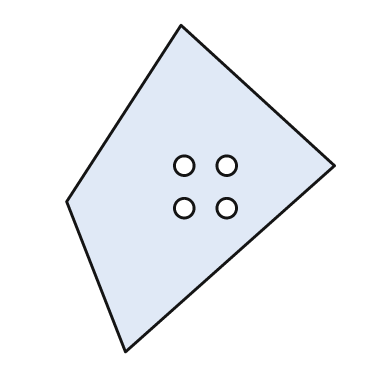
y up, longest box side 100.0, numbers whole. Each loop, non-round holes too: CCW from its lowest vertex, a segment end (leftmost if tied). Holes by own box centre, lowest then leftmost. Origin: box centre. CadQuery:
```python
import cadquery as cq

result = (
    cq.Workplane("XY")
    .moveTo(-23.0, -50.0)
    .lineTo(41.0, 7.0)
    .lineTo(-6.0, 50.0)
    .lineTo(-41.0, -4.0)
    .close()
    .moveTo(-5.0, -6.0)
    .circle(3.0)
    .moveTo(8.0, -6.0)
    .circle(3.0)
    .moveTo(-5.0, 7.0)
    .circle(3.0)
    .moveTo(8.0, 7.0)
    .circle(3.0)
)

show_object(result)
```